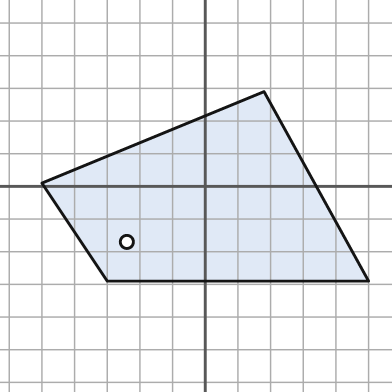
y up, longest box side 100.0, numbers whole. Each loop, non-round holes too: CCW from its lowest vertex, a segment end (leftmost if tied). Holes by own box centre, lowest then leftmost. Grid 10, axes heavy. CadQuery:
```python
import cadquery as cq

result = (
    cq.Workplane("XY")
    .moveTo(-30.0, -29.0)
    .lineTo(50.0, -29.0)
    .lineTo(18.0, 29.0)
    .lineTo(-50.0, 1.0)
    .close()
    .moveTo(-24.0, -17.0)
    .circle(2.0)
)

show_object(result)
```